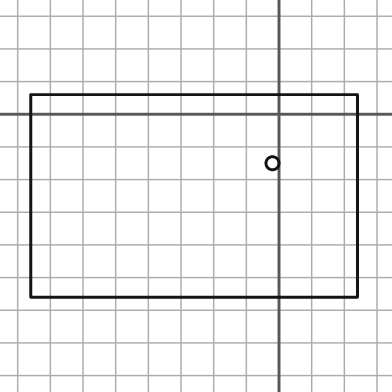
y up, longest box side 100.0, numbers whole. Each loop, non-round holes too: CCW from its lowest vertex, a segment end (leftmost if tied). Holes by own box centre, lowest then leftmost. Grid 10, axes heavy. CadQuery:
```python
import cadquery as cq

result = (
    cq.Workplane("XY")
    .moveTo(-76.0, -56.0)
    .lineTo(24.0, -56.0)
    .lineTo(24.0, 6.0)
    .lineTo(-76.0, 6.0)
    .close()
    .moveTo(-2.0, -15.0)
    .circle(2.0)
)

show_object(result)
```